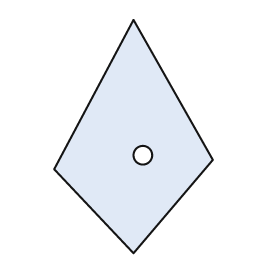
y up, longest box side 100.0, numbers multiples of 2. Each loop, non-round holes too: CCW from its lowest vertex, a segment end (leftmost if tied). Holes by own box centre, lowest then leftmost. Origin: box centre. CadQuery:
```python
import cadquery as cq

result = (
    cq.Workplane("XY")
    .moveTo(0.0, -50.0)
    .lineTo(34.0, -10.0)
    .lineTo(0.0, 50.0)
    .lineTo(-34.0, -14.0)
    .close()
    .moveTo(4.0, -8.0)
    .circle(4.0)
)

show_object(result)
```